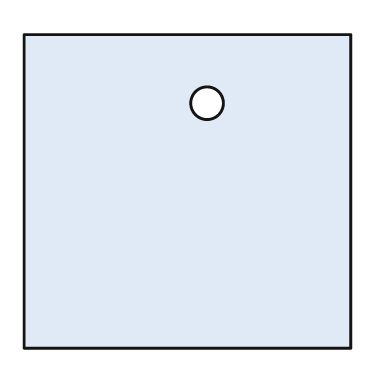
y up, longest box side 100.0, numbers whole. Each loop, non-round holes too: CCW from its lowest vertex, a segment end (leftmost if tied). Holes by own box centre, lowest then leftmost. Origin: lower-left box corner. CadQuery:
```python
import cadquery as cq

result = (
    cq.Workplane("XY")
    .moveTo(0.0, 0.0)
    .lineTo(100.0, 0.0)
    .lineTo(100.0, 96.0)
    .lineTo(0.0, 96.0)
    .close()
    .moveTo(56.0, 75.0)
    .circle(5.0)
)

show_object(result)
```